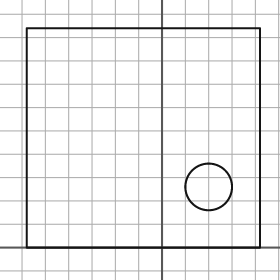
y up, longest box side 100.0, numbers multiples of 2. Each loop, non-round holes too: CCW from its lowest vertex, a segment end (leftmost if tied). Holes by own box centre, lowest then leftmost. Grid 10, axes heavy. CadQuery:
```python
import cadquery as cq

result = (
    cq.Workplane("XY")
    .moveTo(-58.0, 0.0)
    .lineTo(42.0, 0.0)
    .lineTo(42.0, 94.0)
    .lineTo(-58.0, 94.0)
    .close()
    .moveTo(20.0, 26.0)
    .circle(10.0)
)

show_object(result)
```